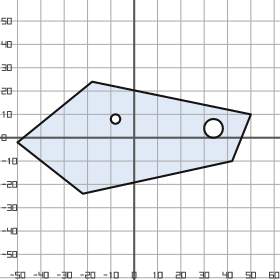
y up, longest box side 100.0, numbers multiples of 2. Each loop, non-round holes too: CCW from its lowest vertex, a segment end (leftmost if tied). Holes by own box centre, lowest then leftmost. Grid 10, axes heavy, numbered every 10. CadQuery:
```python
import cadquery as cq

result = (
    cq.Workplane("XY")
    .moveTo(-22.0, -24.0)
    .lineTo(42.0, -10.0)
    .lineTo(50.0, 10.0)
    .lineTo(-18.0, 24.0)
    .lineTo(-50.0, -2.0)
    .close()
    .moveTo(34.0, 4.0)
    .circle(4.0)
    .moveTo(-8.0, 8.0)
    .circle(2.0)
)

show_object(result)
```